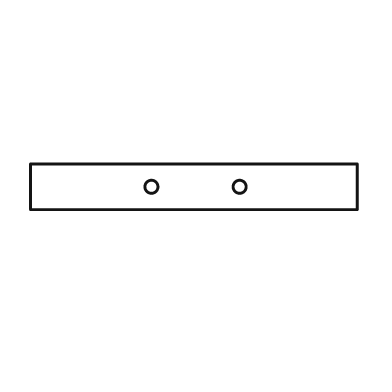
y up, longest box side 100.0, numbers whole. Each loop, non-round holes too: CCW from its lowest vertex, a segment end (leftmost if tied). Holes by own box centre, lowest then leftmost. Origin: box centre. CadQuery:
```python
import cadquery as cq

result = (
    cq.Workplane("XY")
    .moveTo(-50.0, -7.0)
    .lineTo(50.0, -7.0)
    .lineTo(50.0, 7.0)
    .lineTo(-50.0, 7.0)
    .close()
    .moveTo(-13.0, 0.0)
    .circle(2.0)
    .moveTo(14.0, 0.0)
    .circle(2.0)
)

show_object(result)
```